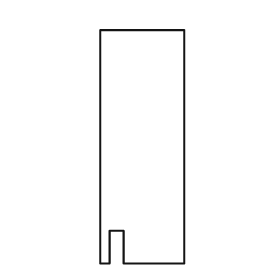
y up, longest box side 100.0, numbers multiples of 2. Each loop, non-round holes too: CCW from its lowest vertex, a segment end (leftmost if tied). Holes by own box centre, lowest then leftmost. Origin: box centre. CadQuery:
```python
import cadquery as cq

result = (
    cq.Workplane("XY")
    .moveTo(-18.0, -50.0)
    .lineTo(-14.0, -50.0)
    .lineTo(-14.0, -36.0)
    .lineTo(-8.0, -36.0)
    .lineTo(-8.0, -50.0)
    .lineTo(18.0, -50.0)
    .lineTo(18.0, 50.0)
    .lineTo(-18.0, 50.0)
    .close()
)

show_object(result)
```